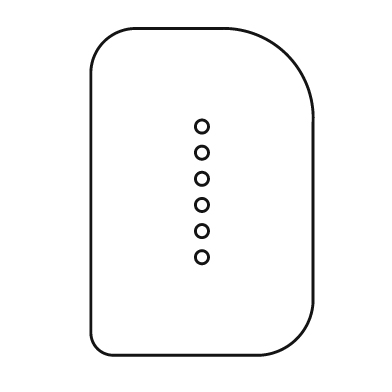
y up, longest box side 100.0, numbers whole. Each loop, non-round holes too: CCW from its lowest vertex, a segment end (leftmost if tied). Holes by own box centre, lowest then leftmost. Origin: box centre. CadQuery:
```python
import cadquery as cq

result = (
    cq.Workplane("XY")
    .moveTo(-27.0, -50.0)
    .lineTo(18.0, -50.0)
    .threePointArc((29.0, -45.0), (34.0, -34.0))
    .lineTo(34.0, 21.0)
    .threePointArc((26.0, 42.0), (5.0, 50.0))
    .lineTo(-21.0, 50.0)
    .threePointArc((-30.0, 46.0), (-34.0, 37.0))
    .lineTo(-34.0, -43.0)
    .threePointArc((-32.0, -48.0), (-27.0, -50.0))
    .close()
    .moveTo(0.0, -20.0)
    .circle(2.0)
    .moveTo(0.0, -12.0)
    .circle(2.0)
    .moveTo(0.0, -4.0)
    .circle(2.0)
    .moveTo(0.0, 4.0)
    .circle(2.0)
    .moveTo(0.0, 12.0)
    .circle(2.0)
    .moveTo(0.0, 20.0)
    .circle(2.0)
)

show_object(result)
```